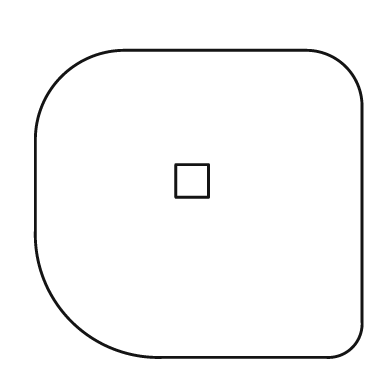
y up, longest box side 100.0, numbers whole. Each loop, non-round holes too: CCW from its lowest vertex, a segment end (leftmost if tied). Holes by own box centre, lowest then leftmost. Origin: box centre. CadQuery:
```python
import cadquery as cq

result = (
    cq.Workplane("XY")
    .moveTo(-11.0, -47.0)
    .lineTo(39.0, -47.0)
    .threePointArc((47.0, -44.0), (50.0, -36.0))
    .lineTo(50.0, 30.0)
    .threePointArc((45.0, 42.0), (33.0, 47.0))
    .lineTo(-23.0, 47.0)
    .threePointArc((-42.0, 39.0), (-50.0, 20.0))
    .lineTo(-50.0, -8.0)
    .threePointArc((-39.0, -36.0), (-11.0, -47.0))
    .close()
    .moveTo(-7.0, 2.0)
    .lineTo(3.0, 2.0)
    .lineTo(3.0, 12.0)
    .lineTo(-7.0, 12.0)
    .close()
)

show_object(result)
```